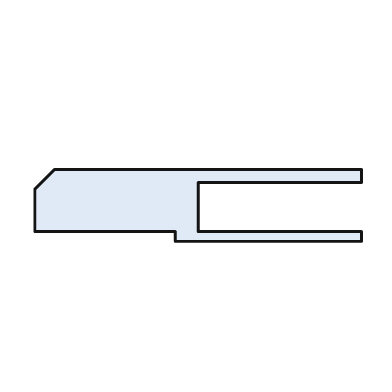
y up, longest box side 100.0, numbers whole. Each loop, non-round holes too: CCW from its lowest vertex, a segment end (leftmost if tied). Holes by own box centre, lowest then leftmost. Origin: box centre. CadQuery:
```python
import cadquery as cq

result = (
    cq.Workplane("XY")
    .moveTo(-7.0, -11.0)
    .lineTo(50.0, -11.0)
    .lineTo(50.0, -8.0)
    .lineTo(0.0, -8.0)
    .lineTo(0.0, 7.0)
    .lineTo(50.0, 7.0)
    .lineTo(50.0, 11.0)
    .lineTo(-44.0, 11.0)
    .lineTo(-50.0, 5.0)
    .lineTo(-50.0, -8.0)
    .lineTo(-7.0, -8.0)
    .close()
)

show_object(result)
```